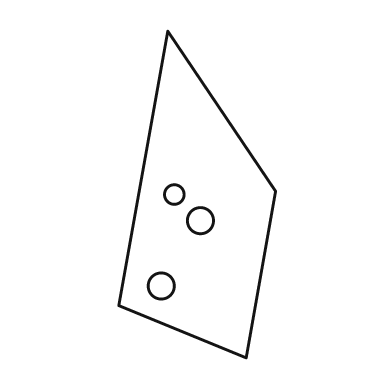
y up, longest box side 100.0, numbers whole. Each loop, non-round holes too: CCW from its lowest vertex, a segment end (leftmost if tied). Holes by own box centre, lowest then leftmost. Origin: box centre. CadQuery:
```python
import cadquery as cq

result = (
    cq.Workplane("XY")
    .moveTo(15.0, -50.0)
    .lineTo(24.0, 1.0)
    .lineTo(-9.0, 50.0)
    .lineTo(-24.0, -34.0)
    .close()
    .moveTo(-11.0, -28.0)
    .circle(4.0)
    .moveTo(1.0, -8.0)
    .circle(4.0)
    .moveTo(-7.0, 0.0)
    .circle(3.0)
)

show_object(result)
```